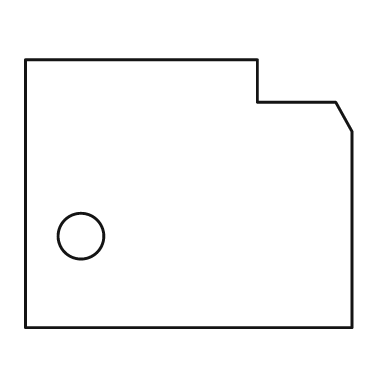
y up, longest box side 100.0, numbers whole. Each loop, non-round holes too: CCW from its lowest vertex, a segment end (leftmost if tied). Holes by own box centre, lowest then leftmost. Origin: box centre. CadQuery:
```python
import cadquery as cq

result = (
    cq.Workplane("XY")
    .moveTo(-50.0, -41.0)
    .lineTo(50.0, -41.0)
    .lineTo(50.0, 19.0)
    .lineTo(45.0, 28.0)
    .lineTo(21.0, 28.0)
    .lineTo(21.0, 41.0)
    .lineTo(-50.0, 41.0)
    .close()
    .moveTo(-33.0, -13.0)
    .circle(7.0)
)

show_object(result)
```